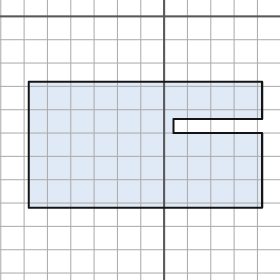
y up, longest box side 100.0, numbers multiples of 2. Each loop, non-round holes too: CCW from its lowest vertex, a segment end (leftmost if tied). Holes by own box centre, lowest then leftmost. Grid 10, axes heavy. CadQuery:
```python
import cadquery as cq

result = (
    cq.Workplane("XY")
    .moveTo(-58.0, -82.0)
    .lineTo(42.0, -82.0)
    .lineTo(42.0, -50.0)
    .lineTo(4.0, -50.0)
    .lineTo(4.0, -44.0)
    .lineTo(42.0, -44.0)
    .lineTo(42.0, -28.0)
    .lineTo(-58.0, -28.0)
    .close()
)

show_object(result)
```